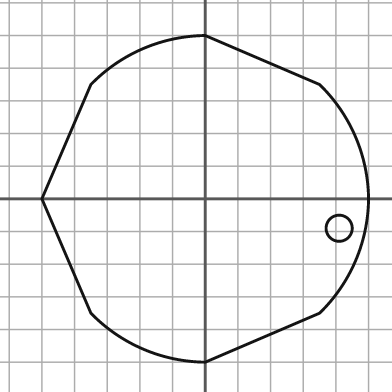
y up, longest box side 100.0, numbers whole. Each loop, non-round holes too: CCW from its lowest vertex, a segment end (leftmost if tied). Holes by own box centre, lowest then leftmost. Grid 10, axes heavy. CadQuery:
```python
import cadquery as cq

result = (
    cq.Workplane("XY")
    .moveTo(0.0, -50.0)
    .lineTo(35.0, -35.0)
    .threePointArc((46.0, -19.0), (50.0, 0.0))
    .threePointArc((46.0, 19.0), (35.0, 35.0))
    .lineTo(0.0, 50.0)
    .threePointArc((-19.0, 46.0), (-35.0, 35.0))
    .lineTo(-50.0, 0.0)
    .lineTo(-35.0, -35.0)
    .threePointArc((-19.0, -46.0), (0.0, -50.0))
    .close()
    .moveTo(41.0, -9.0)
    .circle(4.0)
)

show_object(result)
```